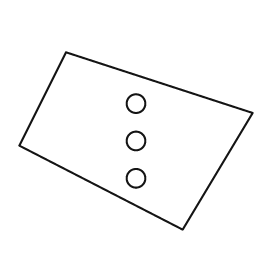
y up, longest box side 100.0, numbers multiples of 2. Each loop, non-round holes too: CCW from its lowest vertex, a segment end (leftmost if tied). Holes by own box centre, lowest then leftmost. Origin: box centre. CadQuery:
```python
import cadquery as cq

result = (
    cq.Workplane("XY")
    .moveTo(20.0, -38.0)
    .lineTo(50.0, 12.0)
    .lineTo(-30.0, 38.0)
    .lineTo(-50.0, -2.0)
    .close()
    .moveTo(0.0, -16.0)
    .circle(4.0)
    .moveTo(0.0, 0.0)
    .circle(4.0)
    .moveTo(0.0, 16.0)
    .circle(4.0)
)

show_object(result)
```